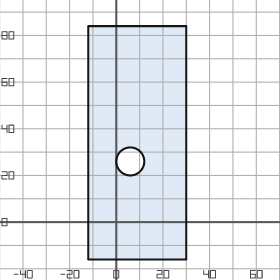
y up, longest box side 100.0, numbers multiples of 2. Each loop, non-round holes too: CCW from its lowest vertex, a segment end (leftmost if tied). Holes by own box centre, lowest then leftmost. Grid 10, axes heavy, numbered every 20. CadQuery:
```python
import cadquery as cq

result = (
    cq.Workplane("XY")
    .moveTo(-12.0, -16.0)
    .lineTo(30.0, -16.0)
    .lineTo(30.0, 84.0)
    .lineTo(-12.0, 84.0)
    .close()
    .moveTo(6.0, 26.0)
    .circle(6.0)
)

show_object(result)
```